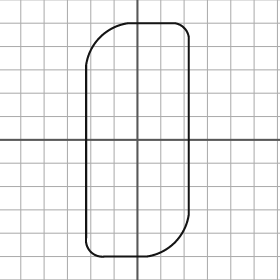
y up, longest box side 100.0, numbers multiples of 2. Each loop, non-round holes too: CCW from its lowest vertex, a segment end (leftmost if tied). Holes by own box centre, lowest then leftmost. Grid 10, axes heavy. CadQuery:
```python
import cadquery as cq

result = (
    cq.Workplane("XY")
    .moveTo(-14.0, -50.0)
    .lineTo(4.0, -50.0)
    .threePointArc((16.0, -44.0), (22.0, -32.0))
    .lineTo(22.0, 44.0)
    .threePointArc((20.0, 48.0), (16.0, 50.0))
    .lineTo(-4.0, 50.0)
    .threePointArc((-16.0, 44.0), (-22.0, 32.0))
    .lineTo(-22.0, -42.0)
    .threePointArc((-20.0, -48.0), (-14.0, -50.0))
    .close()
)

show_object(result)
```